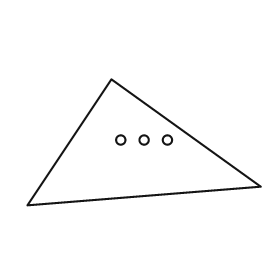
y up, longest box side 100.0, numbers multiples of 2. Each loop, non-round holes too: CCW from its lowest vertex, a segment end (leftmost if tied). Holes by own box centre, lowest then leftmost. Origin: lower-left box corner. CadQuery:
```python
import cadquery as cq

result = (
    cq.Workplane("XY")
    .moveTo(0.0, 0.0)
    .lineTo(100.0, 8.0)
    .lineTo(36.0, 54.0)
    .close()
    .moveTo(40.0, 28.0)
    .circle(2.0)
    .moveTo(50.0, 28.0)
    .circle(2.0)
    .moveTo(60.0, 28.0)
    .circle(2.0)
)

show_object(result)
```